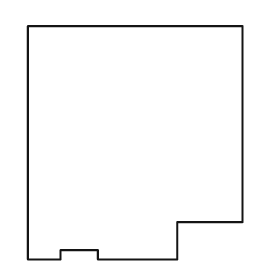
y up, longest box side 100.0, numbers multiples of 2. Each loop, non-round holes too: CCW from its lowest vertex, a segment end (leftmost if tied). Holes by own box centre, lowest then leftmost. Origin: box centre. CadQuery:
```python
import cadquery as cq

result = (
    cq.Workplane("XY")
    .moveTo(-46.0, -50.0)
    .lineTo(-32.0, -50.0)
    .lineTo(-32.0, -46.0)
    .lineTo(-16.0, -46.0)
    .lineTo(-16.0, -50.0)
    .lineTo(18.0, -50.0)
    .lineTo(18.0, -34.0)
    .lineTo(46.0, -34.0)
    .lineTo(46.0, 50.0)
    .lineTo(-46.0, 50.0)
    .close()
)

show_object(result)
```